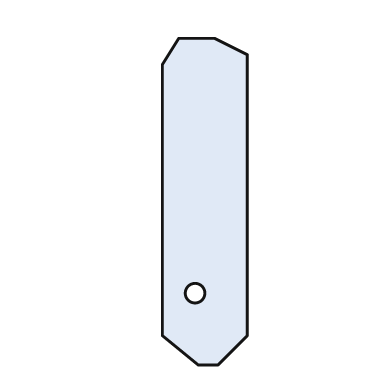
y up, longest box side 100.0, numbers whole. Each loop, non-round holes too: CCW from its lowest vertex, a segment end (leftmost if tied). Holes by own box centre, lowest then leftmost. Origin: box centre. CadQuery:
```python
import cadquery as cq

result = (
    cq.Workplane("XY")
    .moveTo(-2.0, -50.0)
    .lineTo(4.0, -50.0)
    .lineTo(13.0, -41.0)
    .lineTo(13.0, 45.0)
    .lineTo(3.0, 50.0)
    .lineTo(-8.0, 50.0)
    .lineTo(-13.0, 42.0)
    .lineTo(-13.0, -41.0)
    .close()
    .moveTo(-3.0, -28.0)
    .circle(3.0)
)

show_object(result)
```